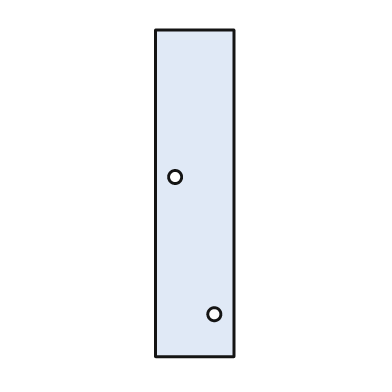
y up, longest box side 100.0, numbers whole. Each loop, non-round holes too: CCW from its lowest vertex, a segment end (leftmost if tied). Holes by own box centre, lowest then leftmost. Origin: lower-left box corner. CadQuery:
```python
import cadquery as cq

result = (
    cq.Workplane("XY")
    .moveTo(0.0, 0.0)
    .lineTo(24.0, 0.0)
    .lineTo(24.0, 100.0)
    .lineTo(0.0, 100.0)
    .close()
    .moveTo(18.0, 13.0)
    .circle(2.0)
    .moveTo(6.0, 55.0)
    .circle(2.0)
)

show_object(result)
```